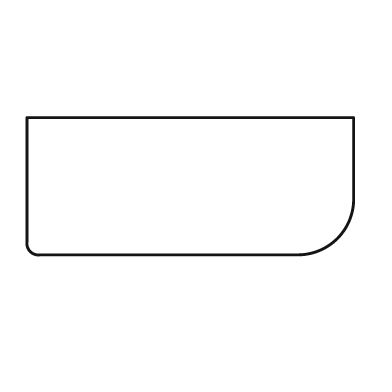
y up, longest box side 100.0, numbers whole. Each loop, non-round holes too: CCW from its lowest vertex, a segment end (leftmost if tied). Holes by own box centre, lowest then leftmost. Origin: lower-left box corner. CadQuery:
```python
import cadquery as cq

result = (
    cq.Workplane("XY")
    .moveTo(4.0, 0.0)
    .lineTo(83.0, 0.0)
    .threePointArc((95.0, 5.0), (100.0, 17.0))
    .lineTo(100.0, 42.0)
    .lineTo(0.0, 42.0)
    .lineTo(0.0, 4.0)
    .threePointArc((1.0, 1.0), (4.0, 0.0))
    .close()
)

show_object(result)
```